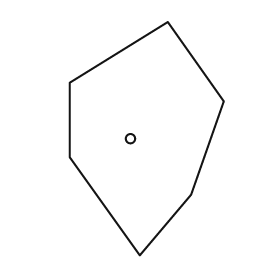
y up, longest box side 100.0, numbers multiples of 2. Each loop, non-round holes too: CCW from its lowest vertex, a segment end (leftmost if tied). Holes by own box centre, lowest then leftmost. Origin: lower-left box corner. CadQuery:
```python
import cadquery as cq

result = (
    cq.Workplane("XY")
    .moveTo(30.0, 0.0)
    .lineTo(52.0, 26.0)
    .lineTo(66.0, 66.0)
    .lineTo(42.0, 100.0)
    .lineTo(0.0, 74.0)
    .lineTo(0.0, 42.0)
    .close()
    .moveTo(26.0, 50.0)
    .circle(2.0)
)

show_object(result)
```